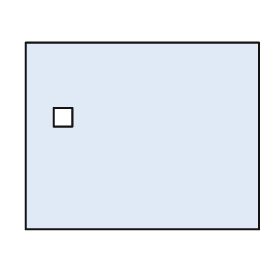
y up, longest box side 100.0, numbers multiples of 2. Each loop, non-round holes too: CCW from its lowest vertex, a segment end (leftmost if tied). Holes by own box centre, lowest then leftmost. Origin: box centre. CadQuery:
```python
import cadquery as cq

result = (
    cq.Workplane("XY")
    .moveTo(-50.0, -40.0)
    .lineTo(50.0, -40.0)
    .lineTo(50.0, 40.0)
    .lineTo(-50.0, 40.0)
    .close()
    .moveTo(-38.0, 4.0)
    .lineTo(-30.0, 4.0)
    .lineTo(-30.0, 12.0)
    .lineTo(-38.0, 12.0)
    .close()
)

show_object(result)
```